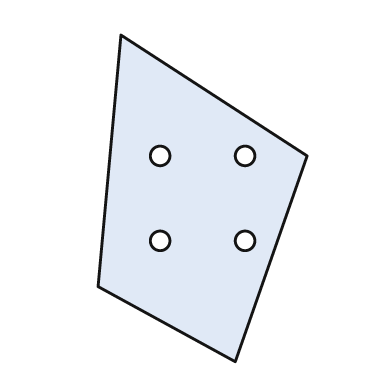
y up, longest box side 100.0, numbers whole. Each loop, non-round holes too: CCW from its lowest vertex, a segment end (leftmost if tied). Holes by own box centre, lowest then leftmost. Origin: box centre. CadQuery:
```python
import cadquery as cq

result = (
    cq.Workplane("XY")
    .moveTo(10.0, -50.0)
    .lineTo(32.0, 13.0)
    .lineTo(-25.0, 50.0)
    .lineTo(-32.0, -27.0)
    .close()
    .moveTo(-13.0, -13.0)
    .circle(3.0)
    .moveTo(13.0, -13.0)
    .circle(3.0)
    .moveTo(-13.0, 13.0)
    .circle(3.0)
    .moveTo(13.0, 13.0)
    .circle(3.0)
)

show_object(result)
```